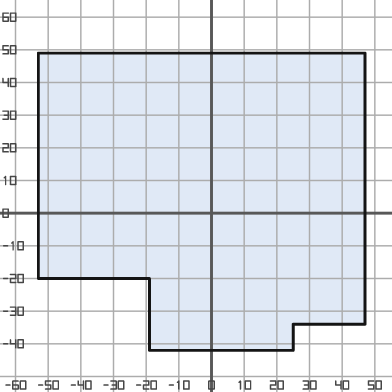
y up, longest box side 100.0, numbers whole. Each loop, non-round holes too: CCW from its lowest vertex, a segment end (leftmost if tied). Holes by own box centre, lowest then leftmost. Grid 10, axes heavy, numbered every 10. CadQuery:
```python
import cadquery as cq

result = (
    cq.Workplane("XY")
    .moveTo(-19.0, -42.0)
    .lineTo(25.0, -42.0)
    .lineTo(25.0, -34.0)
    .lineTo(47.0, -34.0)
    .lineTo(47.0, 49.0)
    .lineTo(-53.0, 49.0)
    .lineTo(-53.0, -20.0)
    .lineTo(-19.0, -20.0)
    .close()
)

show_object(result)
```